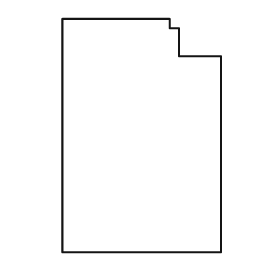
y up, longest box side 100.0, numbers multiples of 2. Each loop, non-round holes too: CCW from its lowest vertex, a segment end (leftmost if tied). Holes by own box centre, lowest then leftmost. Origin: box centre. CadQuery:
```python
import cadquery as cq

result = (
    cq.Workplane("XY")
    .moveTo(-34.0, -50.0)
    .lineTo(34.0, -50.0)
    .lineTo(34.0, 34.0)
    .lineTo(16.0, 34.0)
    .lineTo(16.0, 46.0)
    .lineTo(12.0, 46.0)
    .lineTo(12.0, 50.0)
    .lineTo(-34.0, 50.0)
    .close()
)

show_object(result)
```